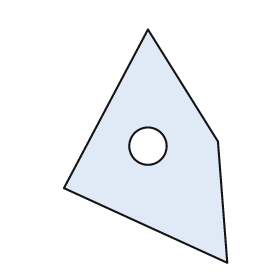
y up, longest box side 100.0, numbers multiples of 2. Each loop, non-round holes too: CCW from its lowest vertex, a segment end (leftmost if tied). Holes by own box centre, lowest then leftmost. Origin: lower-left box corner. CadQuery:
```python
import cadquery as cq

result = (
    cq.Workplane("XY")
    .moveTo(70.0, 0.0)
    .lineTo(66.0, 52.0)
    .lineTo(36.0, 100.0)
    .lineTo(0.0, 32.0)
    .close()
    .moveTo(36.0, 50.0)
    .circle(8.0)
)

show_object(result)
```